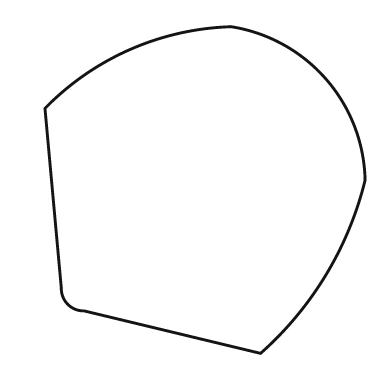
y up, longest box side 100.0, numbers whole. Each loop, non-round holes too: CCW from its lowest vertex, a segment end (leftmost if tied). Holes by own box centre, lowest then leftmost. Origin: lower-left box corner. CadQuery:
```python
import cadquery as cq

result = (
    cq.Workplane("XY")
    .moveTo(66.0, 0.0)
    .threePointArc((86.0, 24.0), (98.0, 53.0))
    .threePointArc((86.0, 84.0), (57.0, 100.0))
    .threePointArc((26.0, 93.0), (0.0, 75.0))
    .lineTo(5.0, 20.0)
    .threePointArc((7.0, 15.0), (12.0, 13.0))
    .close()
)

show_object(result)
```